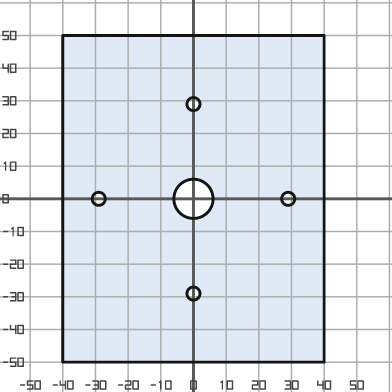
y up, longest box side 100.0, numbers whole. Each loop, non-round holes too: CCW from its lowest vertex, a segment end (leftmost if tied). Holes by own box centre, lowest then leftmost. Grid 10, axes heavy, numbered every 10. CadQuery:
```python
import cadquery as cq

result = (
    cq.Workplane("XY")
    .moveTo(-40.0, -50.0)
    .lineTo(40.0, -50.0)
    .lineTo(40.0, 50.0)
    .lineTo(-40.0, 50.0)
    .close()
    .moveTo(0.0, -29.0)
    .circle(2.0)
    .moveTo(-29.0, 0.0)
    .circle(2.0)
    .moveTo(0.0, 0.0)
    .circle(6.0)
    .moveTo(29.0, 0.0)
    .circle(2.0)
    .moveTo(0.0, 29.0)
    .circle(2.0)
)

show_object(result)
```